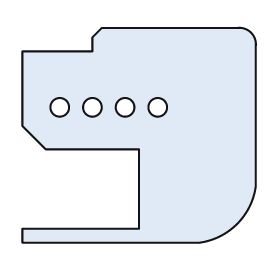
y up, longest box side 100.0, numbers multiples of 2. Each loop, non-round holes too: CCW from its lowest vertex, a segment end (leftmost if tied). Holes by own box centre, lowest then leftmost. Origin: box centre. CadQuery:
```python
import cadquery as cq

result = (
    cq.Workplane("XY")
    .moveTo(-50.0, -46.0)
    .lineTo(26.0, -46.0)
    .threePointArc((42.0, -38.0), (50.0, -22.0))
    .lineTo(50.0, 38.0)
    .threePointArc((48.0, 44.0), (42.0, 46.0))
    .lineTo(-16.0, 46.0)
    .lineTo(-20.0, 42.0)
    .lineTo(-20.0, 36.0)
    .lineTo(-50.0, 36.0)
    .lineTo(-50.0, 4.0)
    .lineTo(-40.0, -6.0)
    .lineTo(0.0, -6.0)
    .lineTo(0.0, -40.0)
    .lineTo(-50.0, -40.0)
    .close()
    .moveTo(-34.0, 12.0)
    .circle(4.0)
    .moveTo(-20.0, 12.0)
    .circle(4.0)
    .moveTo(-6.0, 12.0)
    .circle(4.0)
    .moveTo(8.0, 12.0)
    .circle(4.0)
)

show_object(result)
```